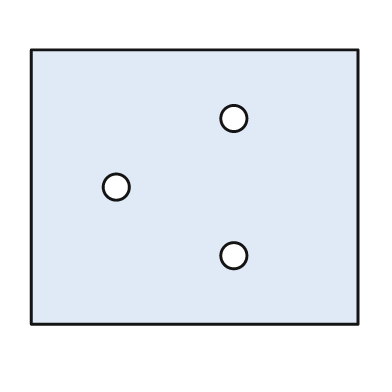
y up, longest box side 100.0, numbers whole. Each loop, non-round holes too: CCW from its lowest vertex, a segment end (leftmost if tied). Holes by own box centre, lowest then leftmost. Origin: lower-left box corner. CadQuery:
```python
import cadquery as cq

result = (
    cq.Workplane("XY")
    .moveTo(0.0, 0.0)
    .lineTo(100.0, 0.0)
    .lineTo(100.0, 84.0)
    .lineTo(0.0, 84.0)
    .close()
    .moveTo(62.0, 21.0)
    .circle(4.0)
    .moveTo(26.0, 42.0)
    .circle(4.0)
    .moveTo(62.0, 63.0)
    .circle(4.0)
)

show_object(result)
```